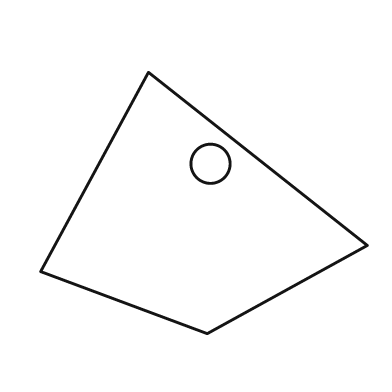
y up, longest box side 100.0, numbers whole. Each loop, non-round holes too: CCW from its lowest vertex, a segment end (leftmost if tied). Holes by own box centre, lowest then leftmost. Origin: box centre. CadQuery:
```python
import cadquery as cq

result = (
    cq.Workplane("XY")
    .moveTo(1.0, -40.0)
    .lineTo(50.0, -13.0)
    .lineTo(-17.0, 40.0)
    .lineTo(-50.0, -21.0)
    .close()
    .moveTo(2.0, 12.0)
    .circle(6.0)
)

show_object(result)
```